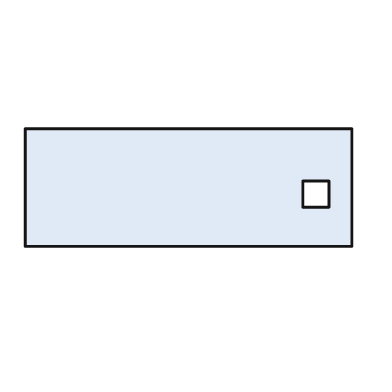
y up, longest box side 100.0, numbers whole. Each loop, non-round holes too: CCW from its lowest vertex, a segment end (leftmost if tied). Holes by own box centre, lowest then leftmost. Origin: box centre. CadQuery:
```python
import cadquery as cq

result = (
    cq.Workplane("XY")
    .moveTo(-50.0, -18.0)
    .lineTo(50.0, -18.0)
    .lineTo(50.0, 18.0)
    .lineTo(-50.0, 18.0)
    .close()
    .moveTo(35.0, -6.0)
    .lineTo(43.0, -6.0)
    .lineTo(43.0, 2.0)
    .lineTo(35.0, 2.0)
    .close()
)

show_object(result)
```